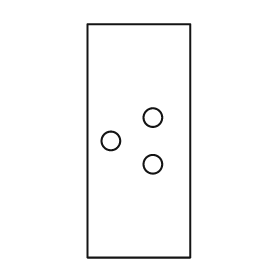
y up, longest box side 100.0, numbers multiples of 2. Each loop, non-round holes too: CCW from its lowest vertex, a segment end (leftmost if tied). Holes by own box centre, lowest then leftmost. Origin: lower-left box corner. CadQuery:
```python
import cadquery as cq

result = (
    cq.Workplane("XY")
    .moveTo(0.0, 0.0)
    .lineTo(44.0, 0.0)
    .lineTo(44.0, 100.0)
    .lineTo(0.0, 100.0)
    .close()
    .moveTo(28.0, 40.0)
    .circle(4.0)
    .moveTo(10.0, 50.0)
    .circle(4.0)
    .moveTo(28.0, 60.0)
    .circle(4.0)
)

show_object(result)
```